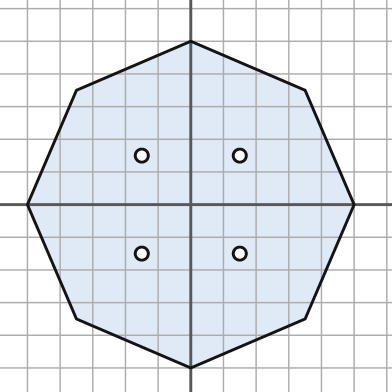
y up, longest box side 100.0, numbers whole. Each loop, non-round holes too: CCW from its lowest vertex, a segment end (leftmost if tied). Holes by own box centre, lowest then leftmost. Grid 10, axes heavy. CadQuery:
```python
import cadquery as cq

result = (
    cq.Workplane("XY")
    .moveTo(0.0, -50.0)
    .lineTo(35.0, -35.0)
    .lineTo(50.0, 0.0)
    .lineTo(35.0, 35.0)
    .lineTo(0.0, 50.0)
    .lineTo(-35.0, 35.0)
    .lineTo(-50.0, 0.0)
    .lineTo(-35.0, -35.0)
    .close()
    .moveTo(-15.0, -15.0)
    .circle(2.0)
    .moveTo(15.0, -15.0)
    .circle(2.0)
    .moveTo(-15.0, 15.0)
    .circle(2.0)
    .moveTo(15.0, 15.0)
    .circle(2.0)
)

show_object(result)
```